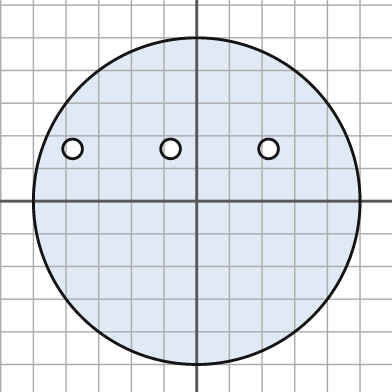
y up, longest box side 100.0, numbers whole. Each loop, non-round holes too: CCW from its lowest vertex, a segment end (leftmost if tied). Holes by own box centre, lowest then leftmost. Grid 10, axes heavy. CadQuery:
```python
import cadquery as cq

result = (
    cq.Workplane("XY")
    .moveTo(0.0, 0.0)
    .circle(50.0)
    .moveTo(-38.0, 16.0)
    .circle(3.0)
    .moveTo(-8.0, 16.0)
    .circle(3.0)
    .moveTo(22.0, 16.0)
    .circle(3.0)
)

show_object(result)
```